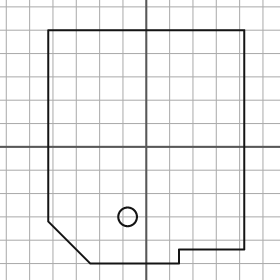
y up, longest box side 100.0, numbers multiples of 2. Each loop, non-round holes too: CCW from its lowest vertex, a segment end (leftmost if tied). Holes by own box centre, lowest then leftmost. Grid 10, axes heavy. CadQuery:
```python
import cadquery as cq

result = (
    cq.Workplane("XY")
    .moveTo(-24.0, -50.0)
    .lineTo(14.0, -50.0)
    .lineTo(14.0, -44.0)
    .lineTo(42.0, -44.0)
    .lineTo(42.0, 50.0)
    .lineTo(-42.0, 50.0)
    .lineTo(-42.0, -32.0)
    .close()
    .moveTo(-8.0, -30.0)
    .circle(4.0)
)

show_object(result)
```